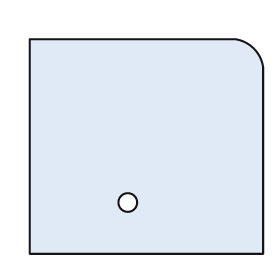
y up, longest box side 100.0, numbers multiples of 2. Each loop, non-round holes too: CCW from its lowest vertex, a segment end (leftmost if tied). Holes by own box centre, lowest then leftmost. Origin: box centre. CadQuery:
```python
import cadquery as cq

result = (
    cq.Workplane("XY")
    .moveTo(-50.0, -46.0)
    .lineTo(50.0, -46.0)
    .lineTo(50.0, 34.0)
    .threePointArc((46.0, 42.0), (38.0, 46.0))
    .lineTo(-50.0, 46.0)
    .close()
    .moveTo(-8.0, -24.0)
    .circle(4.0)
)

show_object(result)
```